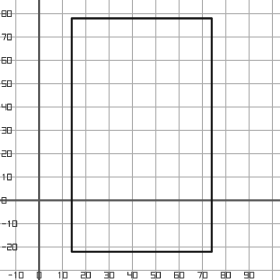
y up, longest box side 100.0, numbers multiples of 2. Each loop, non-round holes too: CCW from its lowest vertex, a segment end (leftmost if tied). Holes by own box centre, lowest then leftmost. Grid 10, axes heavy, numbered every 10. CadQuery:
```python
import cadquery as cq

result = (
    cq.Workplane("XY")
    .moveTo(14.0, -22.0)
    .lineTo(74.0, -22.0)
    .lineTo(74.0, 78.0)
    .lineTo(14.0, 78.0)
    .close()
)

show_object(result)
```